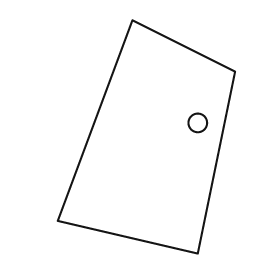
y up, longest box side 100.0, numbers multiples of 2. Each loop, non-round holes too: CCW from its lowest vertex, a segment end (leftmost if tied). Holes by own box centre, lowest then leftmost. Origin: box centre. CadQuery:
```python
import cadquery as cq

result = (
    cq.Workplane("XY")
    .moveTo(22.0, -50.0)
    .lineTo(38.0, 28.0)
    .lineTo(-6.0, 50.0)
    .lineTo(-38.0, -36.0)
    .close()
    .moveTo(22.0, 6.0)
    .circle(4.0)
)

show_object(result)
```